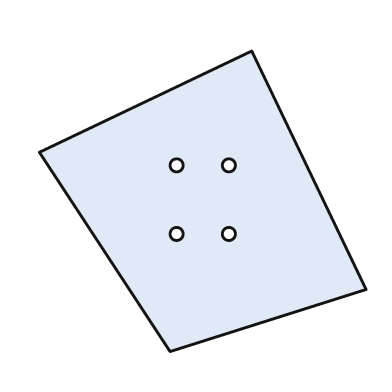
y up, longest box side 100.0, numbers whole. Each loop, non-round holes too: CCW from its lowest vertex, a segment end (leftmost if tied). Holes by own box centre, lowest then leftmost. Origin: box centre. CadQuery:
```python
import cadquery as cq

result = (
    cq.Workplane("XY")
    .moveTo(-10.0, -46.0)
    .lineTo(50.0, -27.0)
    .lineTo(15.0, 46.0)
    .lineTo(-50.0, 15.0)
    .close()
    .moveTo(-8.0, -10.0)
    .circle(2.0)
    .moveTo(8.0, -10.0)
    .circle(2.0)
    .moveTo(-8.0, 11.0)
    .circle(2.0)
    .moveTo(8.0, 11.0)
    .circle(2.0)
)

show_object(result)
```